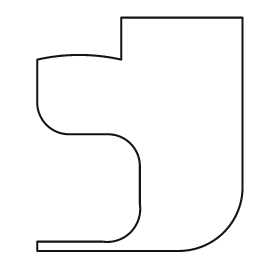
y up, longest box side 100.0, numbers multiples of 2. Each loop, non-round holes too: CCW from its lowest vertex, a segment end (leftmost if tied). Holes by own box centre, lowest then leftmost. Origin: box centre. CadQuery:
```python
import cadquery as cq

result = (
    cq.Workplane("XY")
    .moveTo(-44.0, -50.0)
    .lineTo(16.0, -50.0)
    .threePointArc((36.0, -42.0), (44.0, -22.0))
    .lineTo(44.0, 50.0)
    .lineTo(-8.0, 50.0)
    .lineTo(-8.0, 32.0)
    .threePointArc((-26.0, 34.0), (-44.0, 32.0))
    .lineTo(-44.0, 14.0)
    .threePointArc((-40.0, 4.0), (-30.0, 0.0))
    .lineTo(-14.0, 0.0)
    .threePointArc((-4.0, -4.0), (0.0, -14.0))
    .lineTo(0.0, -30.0)
    .threePointArc((-4.0, -42.0), (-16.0, -46.0))
    .lineTo(-44.0, -46.0)
    .close()
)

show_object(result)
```